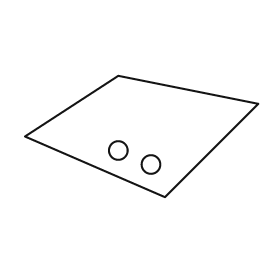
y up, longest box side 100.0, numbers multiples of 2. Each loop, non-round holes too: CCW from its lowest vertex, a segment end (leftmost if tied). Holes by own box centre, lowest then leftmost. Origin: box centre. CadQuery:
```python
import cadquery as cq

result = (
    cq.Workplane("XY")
    .moveTo(10.0, -26.0)
    .lineTo(50.0, 14.0)
    .lineTo(-10.0, 26.0)
    .lineTo(-50.0, 0.0)
    .close()
    .moveTo(4.0, -12.0)
    .circle(4.0)
    .moveTo(-10.0, -6.0)
    .circle(4.0)
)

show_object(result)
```